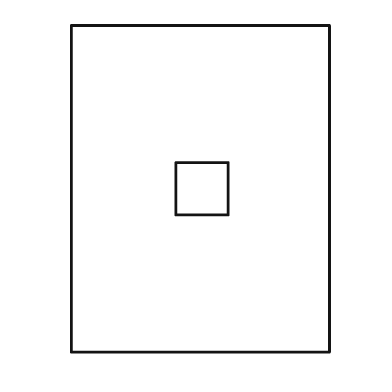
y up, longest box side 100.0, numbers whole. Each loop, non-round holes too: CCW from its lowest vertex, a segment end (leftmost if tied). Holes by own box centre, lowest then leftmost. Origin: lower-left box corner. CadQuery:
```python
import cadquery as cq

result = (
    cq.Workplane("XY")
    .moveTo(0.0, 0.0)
    .lineTo(79.0, 0.0)
    .lineTo(79.0, 100.0)
    .lineTo(0.0, 100.0)
    .close()
    .moveTo(32.0, 42.0)
    .lineTo(48.0, 42.0)
    .lineTo(48.0, 58.0)
    .lineTo(32.0, 58.0)
    .close()
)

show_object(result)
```